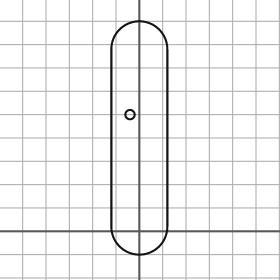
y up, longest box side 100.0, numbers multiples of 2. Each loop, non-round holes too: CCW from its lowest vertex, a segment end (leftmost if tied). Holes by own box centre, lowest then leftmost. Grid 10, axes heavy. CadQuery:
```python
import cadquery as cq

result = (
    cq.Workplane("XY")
    .moveTo(-12.0, 2.0)
    .threePointArc((0.0, -10.0), (12.0, 2.0))
    .lineTo(12.0, 78.0)
    .threePointArc((0.0, 90.0), (-12.0, 78.0))
    .close()
    .moveTo(-4.0, 50.0)
    .circle(2.0)
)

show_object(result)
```